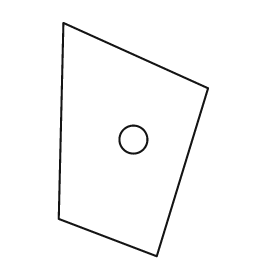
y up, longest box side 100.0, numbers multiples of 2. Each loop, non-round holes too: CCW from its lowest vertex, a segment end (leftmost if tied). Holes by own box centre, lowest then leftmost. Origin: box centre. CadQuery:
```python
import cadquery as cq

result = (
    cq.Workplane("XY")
    .moveTo(10.0, -50.0)
    .lineTo(32.0, 22.0)
    .lineTo(-30.0, 50.0)
    .lineTo(-32.0, -34.0)
    .close()
    .moveTo(0.0, 0.0)
    .circle(6.0)
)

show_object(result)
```